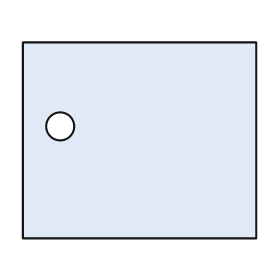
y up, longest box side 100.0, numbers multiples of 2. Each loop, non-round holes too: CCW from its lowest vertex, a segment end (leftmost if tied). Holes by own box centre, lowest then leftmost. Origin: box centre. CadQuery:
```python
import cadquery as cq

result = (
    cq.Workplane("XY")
    .moveTo(-50.0, -42.0)
    .lineTo(50.0, -42.0)
    .lineTo(50.0, 42.0)
    .lineTo(-50.0, 42.0)
    .close()
    .moveTo(-34.0, 6.0)
    .circle(6.0)
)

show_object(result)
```